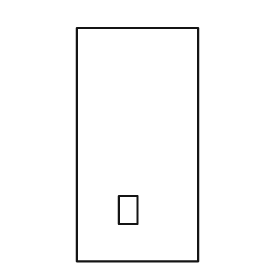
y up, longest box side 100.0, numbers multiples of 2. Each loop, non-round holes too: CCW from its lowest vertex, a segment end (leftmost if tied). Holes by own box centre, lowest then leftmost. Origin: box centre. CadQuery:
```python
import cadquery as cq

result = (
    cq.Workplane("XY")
    .moveTo(-26.0, -50.0)
    .lineTo(26.0, -50.0)
    .lineTo(26.0, 50.0)
    .lineTo(-26.0, 50.0)
    .close()
    .moveTo(-8.0, -34.0)
    .lineTo(0.0, -34.0)
    .lineTo(0.0, -22.0)
    .lineTo(-8.0, -22.0)
    .close()
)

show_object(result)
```